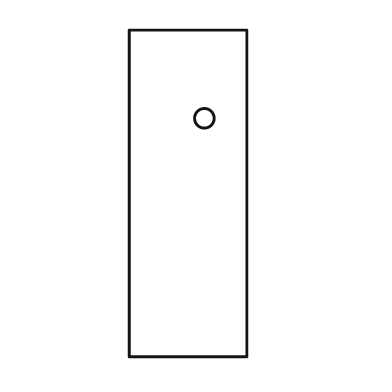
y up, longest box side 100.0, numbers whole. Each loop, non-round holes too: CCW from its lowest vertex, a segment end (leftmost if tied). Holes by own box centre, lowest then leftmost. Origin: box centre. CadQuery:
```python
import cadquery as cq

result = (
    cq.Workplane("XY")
    .moveTo(-18.0, -50.0)
    .lineTo(18.0, -50.0)
    .lineTo(18.0, 50.0)
    .lineTo(-18.0, 50.0)
    .close()
    .moveTo(5.0, 23.0)
    .circle(3.0)
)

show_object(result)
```